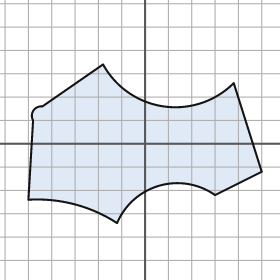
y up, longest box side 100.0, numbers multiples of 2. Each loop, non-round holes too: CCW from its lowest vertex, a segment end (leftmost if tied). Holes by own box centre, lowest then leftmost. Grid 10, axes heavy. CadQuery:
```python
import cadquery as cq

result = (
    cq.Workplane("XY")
    .moveTo(-12.0, -34.0)
    .threePointArc((6.0, -18.0), (30.0, -22.0))
    .lineTo(50.0, -12.0)
    .lineTo(38.0, 26.0)
    .threePointArc((8.0, 16.0), (-18.0, 34.0))
    .lineTo(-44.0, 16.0)
    .threePointArc((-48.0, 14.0), (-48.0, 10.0))
    .lineTo(-50.0, -24.0)
    .threePointArc((-30.0, -26.0), (-12.0, -34.0))
    .close()
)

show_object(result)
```